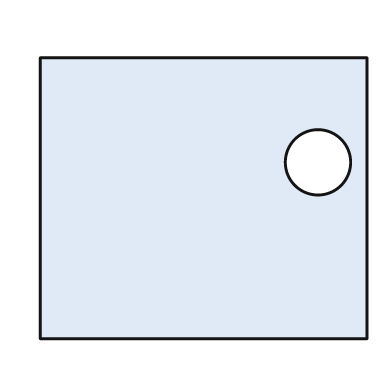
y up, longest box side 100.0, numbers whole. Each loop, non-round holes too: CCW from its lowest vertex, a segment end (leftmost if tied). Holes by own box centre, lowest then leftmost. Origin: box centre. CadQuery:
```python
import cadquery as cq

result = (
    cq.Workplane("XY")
    .moveTo(-50.0, -43.0)
    .lineTo(50.0, -43.0)
    .lineTo(50.0, 43.0)
    .lineTo(-50.0, 43.0)
    .close()
    .moveTo(35.0, 11.0)
    .circle(10.0)
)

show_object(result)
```